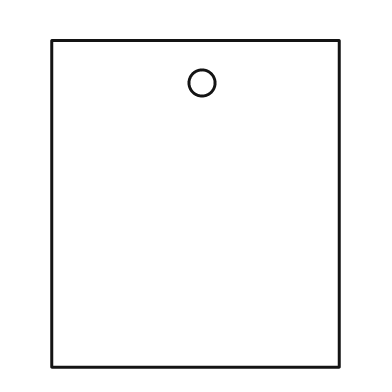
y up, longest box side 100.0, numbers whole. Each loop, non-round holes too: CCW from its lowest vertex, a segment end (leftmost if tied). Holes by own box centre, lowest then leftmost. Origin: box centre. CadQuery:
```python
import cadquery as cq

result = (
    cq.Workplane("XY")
    .moveTo(-44.0, -50.0)
    .lineTo(44.0, -50.0)
    .lineTo(44.0, 50.0)
    .lineTo(-44.0, 50.0)
    .close()
    .moveTo(2.0, 37.0)
    .circle(4.0)
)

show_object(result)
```